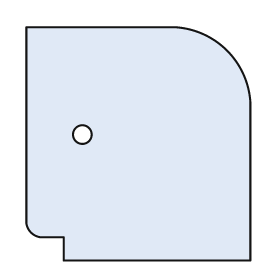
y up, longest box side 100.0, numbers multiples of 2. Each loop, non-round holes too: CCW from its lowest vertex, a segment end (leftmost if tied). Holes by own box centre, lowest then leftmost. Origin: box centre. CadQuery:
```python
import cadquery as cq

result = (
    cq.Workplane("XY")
    .moveTo(-32.0, -50.0)
    .lineTo(48.0, -50.0)
    .lineTo(48.0, 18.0)
    .threePointArc((38.0, 40.0), (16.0, 50.0))
    .lineTo(-48.0, 50.0)
    .lineTo(-48.0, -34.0)
    .threePointArc((-46.0, -38.0), (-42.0, -40.0))
    .lineTo(-32.0, -40.0)
    .close()
    .moveTo(-24.0, 4.0)
    .circle(4.0)
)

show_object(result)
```